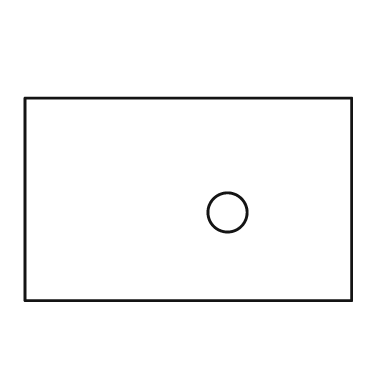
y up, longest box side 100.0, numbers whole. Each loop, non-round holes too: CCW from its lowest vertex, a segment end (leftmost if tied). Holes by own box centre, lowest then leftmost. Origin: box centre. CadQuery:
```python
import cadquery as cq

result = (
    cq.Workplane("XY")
    .moveTo(-50.0, -31.0)
    .lineTo(50.0, -31.0)
    .lineTo(50.0, 31.0)
    .lineTo(-50.0, 31.0)
    .close()
    .moveTo(12.0, -4.0)
    .circle(6.0)
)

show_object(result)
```